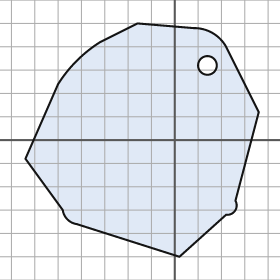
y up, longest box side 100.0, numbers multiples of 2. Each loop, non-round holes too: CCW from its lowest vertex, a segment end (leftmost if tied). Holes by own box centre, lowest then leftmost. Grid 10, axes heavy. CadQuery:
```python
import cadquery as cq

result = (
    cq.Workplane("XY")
    .moveTo(2.0, -50.0)
    .lineTo(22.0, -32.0)
    .threePointArc((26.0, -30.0), (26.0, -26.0))
    .lineTo(36.0, 12.0)
    .lineTo(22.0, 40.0)
    .threePointArc((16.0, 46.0), (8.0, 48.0))
    .lineTo(-16.0, 50.0)
    .lineTo(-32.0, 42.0)
    .threePointArc((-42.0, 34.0), (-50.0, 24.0))
    .lineTo(-64.0, -8.0)
    .lineTo(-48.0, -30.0)
    .threePointArc((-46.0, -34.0), (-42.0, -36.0))
    .close()
    .moveTo(14.0, 32.0)
    .circle(4.0)
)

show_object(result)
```